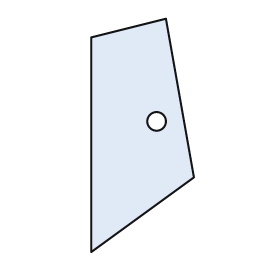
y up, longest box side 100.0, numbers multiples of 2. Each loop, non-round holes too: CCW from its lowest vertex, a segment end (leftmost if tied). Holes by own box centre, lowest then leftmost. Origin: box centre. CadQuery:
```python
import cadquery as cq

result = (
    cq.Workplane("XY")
    .moveTo(-22.0, -50.0)
    .lineTo(22.0, -18.0)
    .lineTo(10.0, 50.0)
    .lineTo(-22.0, 42.0)
    .close()
    .moveTo(6.0, 6.0)
    .circle(4.0)
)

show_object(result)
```